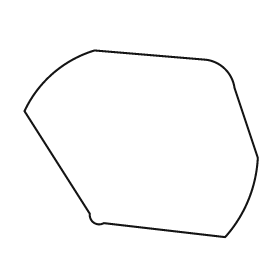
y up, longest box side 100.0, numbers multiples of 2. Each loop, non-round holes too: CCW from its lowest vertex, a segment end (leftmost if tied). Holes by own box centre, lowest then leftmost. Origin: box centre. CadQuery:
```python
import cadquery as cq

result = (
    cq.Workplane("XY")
    .moveTo(36.0, -40.0)
    .threePointArc((46.0, -24.0), (50.0, -6.0))
    .lineTo(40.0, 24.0)
    .threePointArc((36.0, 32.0), (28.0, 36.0))
    .lineTo(-20.0, 40.0)
    .threePointArc((-38.0, 30.0), (-50.0, 14.0))
    .lineTo(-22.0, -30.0)
    .threePointArc((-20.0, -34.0), (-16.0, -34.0))
    .close()
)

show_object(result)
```